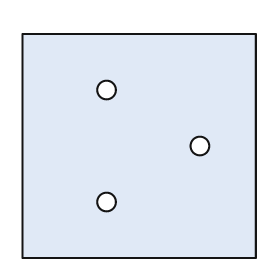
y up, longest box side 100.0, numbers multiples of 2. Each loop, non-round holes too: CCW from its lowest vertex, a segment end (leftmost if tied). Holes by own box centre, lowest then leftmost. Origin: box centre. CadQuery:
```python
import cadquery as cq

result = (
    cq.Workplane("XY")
    .moveTo(-50.0, -48.0)
    .lineTo(50.0, -48.0)
    .lineTo(50.0, 48.0)
    .lineTo(-50.0, 48.0)
    .close()
    .moveTo(-14.0, -24.0)
    .circle(4.0)
    .moveTo(26.0, 0.0)
    .circle(4.0)
    .moveTo(-14.0, 24.0)
    .circle(4.0)
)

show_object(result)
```